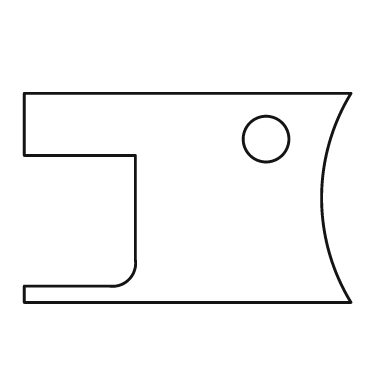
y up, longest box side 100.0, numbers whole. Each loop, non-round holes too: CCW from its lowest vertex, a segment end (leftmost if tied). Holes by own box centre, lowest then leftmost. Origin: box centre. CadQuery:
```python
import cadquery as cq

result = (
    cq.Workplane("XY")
    .moveTo(-50.0, -32.0)
    .lineTo(50.0, -32.0)
    .threePointArc((41.0, 0.0), (50.0, 32.0))
    .lineTo(-50.0, 32.0)
    .lineTo(-50.0, 13.0)
    .lineTo(-16.0, 13.0)
    .lineTo(-16.0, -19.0)
    .threePointArc((-18.0, -25.0), (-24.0, -27.0))
    .lineTo(-50.0, -27.0)
    .close()
    .moveTo(24.0, 18.0)
    .circle(7.0)
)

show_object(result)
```